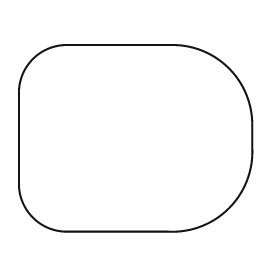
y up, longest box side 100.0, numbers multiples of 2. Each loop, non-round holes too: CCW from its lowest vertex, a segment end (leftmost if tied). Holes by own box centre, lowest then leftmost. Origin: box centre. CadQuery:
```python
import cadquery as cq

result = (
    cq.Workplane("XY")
    .moveTo(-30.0, -40.0)
    .lineTo(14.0, -40.0)
    .threePointArc((40.0, -30.0), (50.0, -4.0))
    .lineTo(50.0, 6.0)
    .threePointArc((40.0, 30.0), (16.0, 40.0))
    .lineTo(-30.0, 40.0)
    .threePointArc((-44.0, 34.0), (-50.0, 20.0))
    .lineTo(-50.0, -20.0)
    .threePointArc((-44.0, -34.0), (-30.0, -40.0))
    .close()
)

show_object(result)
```